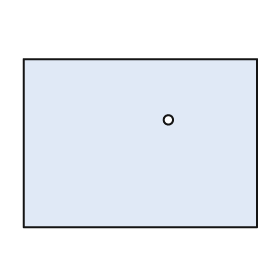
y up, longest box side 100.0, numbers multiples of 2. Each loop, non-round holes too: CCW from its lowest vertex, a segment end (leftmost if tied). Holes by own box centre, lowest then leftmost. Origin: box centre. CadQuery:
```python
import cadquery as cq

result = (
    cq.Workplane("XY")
    .moveTo(-50.0, -36.0)
    .lineTo(50.0, -36.0)
    .lineTo(50.0, 36.0)
    .lineTo(-50.0, 36.0)
    .close()
    .moveTo(12.0, 10.0)
    .circle(2.0)
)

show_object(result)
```